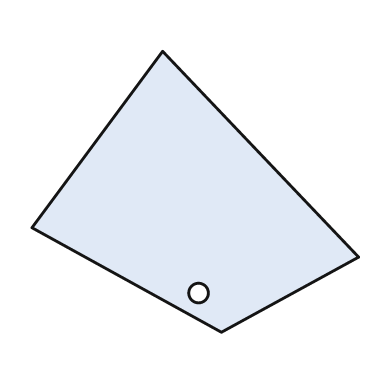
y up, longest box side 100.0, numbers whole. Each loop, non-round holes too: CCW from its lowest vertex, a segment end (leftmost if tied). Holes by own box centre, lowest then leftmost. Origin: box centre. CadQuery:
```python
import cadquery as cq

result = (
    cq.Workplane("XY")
    .moveTo(8.0, -43.0)
    .lineTo(50.0, -20.0)
    .lineTo(-10.0, 43.0)
    .lineTo(-50.0, -11.0)
    .close()
    .moveTo(1.0, -31.0)
    .circle(3.0)
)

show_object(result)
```